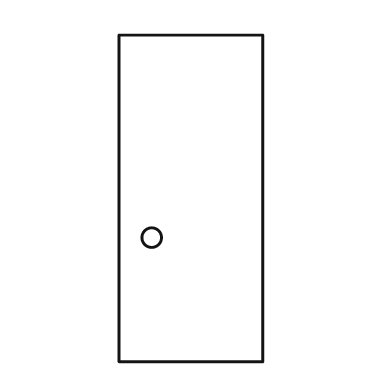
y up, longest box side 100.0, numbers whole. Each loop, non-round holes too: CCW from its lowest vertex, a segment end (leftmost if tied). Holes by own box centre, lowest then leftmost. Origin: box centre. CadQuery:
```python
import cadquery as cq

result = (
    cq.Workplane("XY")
    .moveTo(-22.0, -50.0)
    .lineTo(22.0, -50.0)
    .lineTo(22.0, 50.0)
    .lineTo(-22.0, 50.0)
    .close()
    .moveTo(-12.0, -12.0)
    .circle(3.0)
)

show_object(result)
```